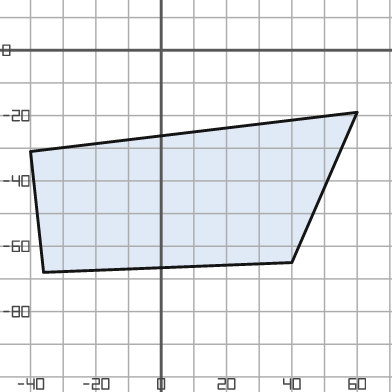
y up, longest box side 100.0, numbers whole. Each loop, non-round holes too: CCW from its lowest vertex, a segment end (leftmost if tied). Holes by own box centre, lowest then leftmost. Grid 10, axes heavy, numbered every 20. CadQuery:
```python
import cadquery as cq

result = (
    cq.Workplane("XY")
    .moveTo(-36.0, -68.0)
    .lineTo(40.0, -65.0)
    .lineTo(60.0, -19.0)
    .lineTo(-40.0, -31.0)
    .close()
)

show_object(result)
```